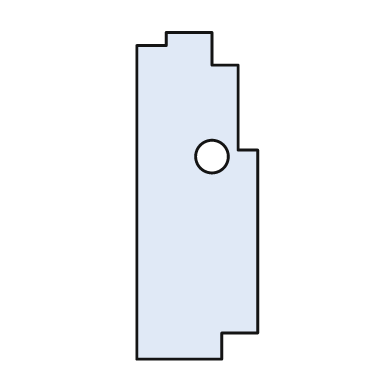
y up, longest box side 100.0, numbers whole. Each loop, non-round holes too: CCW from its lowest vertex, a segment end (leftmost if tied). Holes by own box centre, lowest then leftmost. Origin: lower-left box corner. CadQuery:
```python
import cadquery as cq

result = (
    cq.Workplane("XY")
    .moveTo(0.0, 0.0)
    .lineTo(26.0, 0.0)
    .lineTo(26.0, 8.0)
    .lineTo(37.0, 8.0)
    .lineTo(37.0, 64.0)
    .lineTo(31.0, 64.0)
    .lineTo(31.0, 90.0)
    .lineTo(23.0, 90.0)
    .lineTo(23.0, 100.0)
    .lineTo(9.0, 100.0)
    .lineTo(9.0, 96.0)
    .lineTo(0.0, 96.0)
    .close()
    .moveTo(23.0, 62.0)
    .circle(5.0)
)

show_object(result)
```